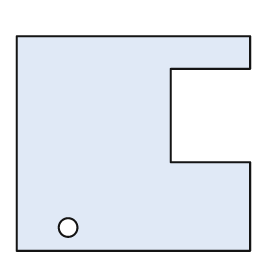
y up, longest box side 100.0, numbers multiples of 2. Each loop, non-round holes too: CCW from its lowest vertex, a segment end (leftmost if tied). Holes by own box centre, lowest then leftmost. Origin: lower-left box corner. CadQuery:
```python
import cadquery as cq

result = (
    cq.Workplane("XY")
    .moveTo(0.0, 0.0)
    .lineTo(100.0, 0.0)
    .lineTo(100.0, 38.0)
    .lineTo(66.0, 38.0)
    .lineTo(66.0, 78.0)
    .lineTo(100.0, 78.0)
    .lineTo(100.0, 92.0)
    .lineTo(0.0, 92.0)
    .close()
    .moveTo(22.0, 10.0)
    .circle(4.0)
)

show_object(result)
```